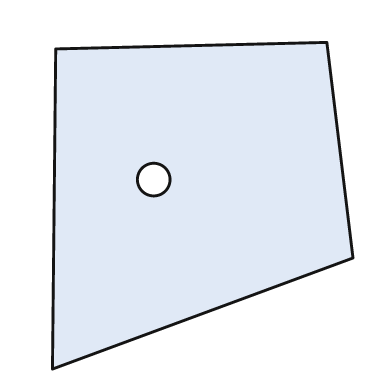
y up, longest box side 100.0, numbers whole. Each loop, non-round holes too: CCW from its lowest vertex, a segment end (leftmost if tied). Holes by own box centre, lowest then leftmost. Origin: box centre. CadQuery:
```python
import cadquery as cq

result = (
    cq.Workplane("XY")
    .moveTo(-46.0, -50.0)
    .lineTo(46.0, -16.0)
    .lineTo(38.0, 50.0)
    .lineTo(-45.0, 48.0)
    .close()
    .moveTo(-15.0, 8.0)
    .circle(5.0)
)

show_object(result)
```